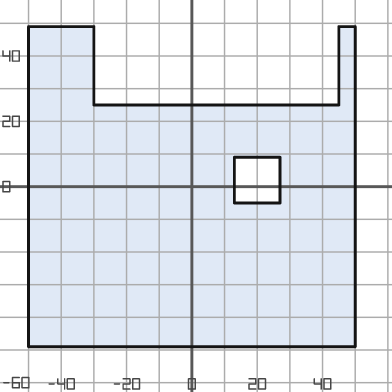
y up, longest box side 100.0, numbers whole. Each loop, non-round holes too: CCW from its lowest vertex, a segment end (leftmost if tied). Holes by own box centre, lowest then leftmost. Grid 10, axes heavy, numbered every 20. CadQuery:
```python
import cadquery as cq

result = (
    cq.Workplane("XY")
    .moveTo(-50.0, -49.0)
    .lineTo(50.0, -49.0)
    .lineTo(50.0, 49.0)
    .lineTo(45.0, 49.0)
    .lineTo(45.0, 25.0)
    .lineTo(-30.0, 25.0)
    .lineTo(-30.0, 49.0)
    .lineTo(-50.0, 49.0)
    .close()
    .moveTo(13.0, -5.0)
    .lineTo(27.0, -5.0)
    .lineTo(27.0, 9.0)
    .lineTo(13.0, 9.0)
    .close()
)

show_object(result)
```